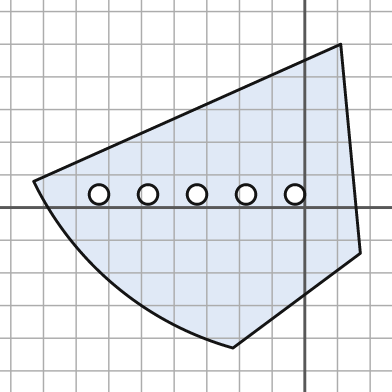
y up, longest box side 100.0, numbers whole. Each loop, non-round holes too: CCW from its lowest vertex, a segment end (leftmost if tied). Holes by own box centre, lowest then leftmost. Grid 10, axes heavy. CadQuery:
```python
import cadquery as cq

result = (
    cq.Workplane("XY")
    .moveTo(-22.0, -43.0)
    .lineTo(17.0, -14.0)
    .lineTo(11.0, 50.0)
    .lineTo(-83.0, 8.0)
    .threePointArc((-58.0, -24.0), (-22.0, -43.0))
    .close()
    .moveTo(-63.0, 4.0)
    .circle(3.0)
    .moveTo(-48.0, 4.0)
    .circle(3.0)
    .moveTo(-33.0, 4.0)
    .circle(3.0)
    .moveTo(-18.0, 4.0)
    .circle(3.0)
    .moveTo(-3.0, 4.0)
    .circle(3.0)
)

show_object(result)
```